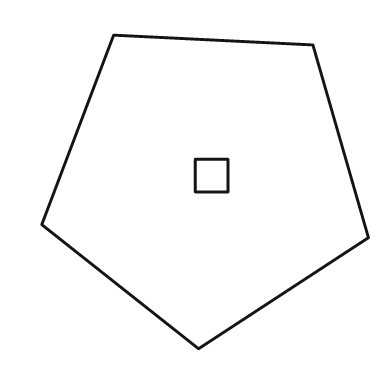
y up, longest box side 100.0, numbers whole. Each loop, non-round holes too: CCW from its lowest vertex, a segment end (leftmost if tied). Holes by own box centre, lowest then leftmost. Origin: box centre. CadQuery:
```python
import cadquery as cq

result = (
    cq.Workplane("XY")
    .moveTo(-2.0, -48.0)
    .lineTo(50.0, -14.0)
    .lineTo(33.0, 45.0)
    .lineTo(-28.0, 48.0)
    .lineTo(-50.0, -10.0)
    .close()
    .moveTo(-3.0, 0.0)
    .lineTo(7.0, 0.0)
    .lineTo(7.0, 10.0)
    .lineTo(-3.0, 10.0)
    .close()
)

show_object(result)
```